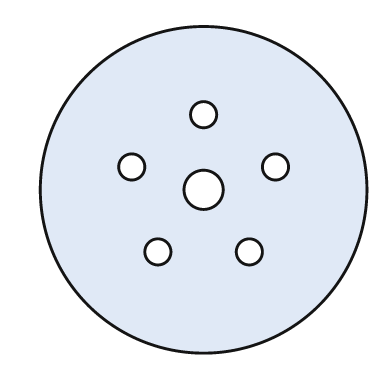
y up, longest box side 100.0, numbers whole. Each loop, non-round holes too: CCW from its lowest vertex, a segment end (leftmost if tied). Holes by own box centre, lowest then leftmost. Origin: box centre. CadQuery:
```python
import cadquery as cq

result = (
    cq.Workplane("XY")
    .moveTo(0.0, 0.0)
    .circle(50.0)
    .moveTo(-14.0, -19.0)
    .circle(4.0)
    .moveTo(14.0, -19.0)
    .circle(4.0)
    .moveTo(0.0, 0.0)
    .circle(6.0)
    .moveTo(-22.0, 7.0)
    .circle(4.0)
    .moveTo(22.0, 7.0)
    .circle(4.0)
    .moveTo(0.0, 23.0)
    .circle(4.0)
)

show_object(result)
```